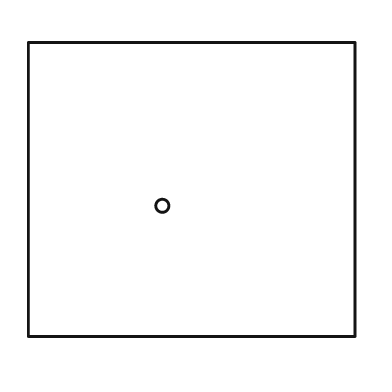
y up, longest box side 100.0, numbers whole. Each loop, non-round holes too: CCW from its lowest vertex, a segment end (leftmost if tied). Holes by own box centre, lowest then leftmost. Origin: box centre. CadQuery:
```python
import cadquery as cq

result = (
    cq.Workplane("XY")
    .moveTo(-50.0, -45.0)
    .lineTo(50.0, -45.0)
    .lineTo(50.0, 45.0)
    .lineTo(-50.0, 45.0)
    .close()
    .moveTo(-9.0, -5.0)
    .circle(2.0)
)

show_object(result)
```